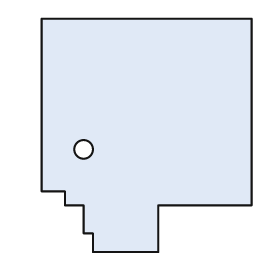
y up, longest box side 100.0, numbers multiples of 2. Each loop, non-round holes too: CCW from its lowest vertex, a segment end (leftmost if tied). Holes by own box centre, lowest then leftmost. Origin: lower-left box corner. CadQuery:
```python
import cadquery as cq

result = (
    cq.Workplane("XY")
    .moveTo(22.0, 0.0)
    .lineTo(50.0, 0.0)
    .lineTo(50.0, 20.0)
    .lineTo(90.0, 20.0)
    .lineTo(90.0, 100.0)
    .lineTo(0.0, 100.0)
    .lineTo(0.0, 26.0)
    .lineTo(10.0, 26.0)
    .lineTo(10.0, 20.0)
    .lineTo(18.0, 20.0)
    .lineTo(18.0, 8.0)
    .lineTo(22.0, 8.0)
    .close()
    .moveTo(18.0, 44.0)
    .circle(4.0)
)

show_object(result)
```